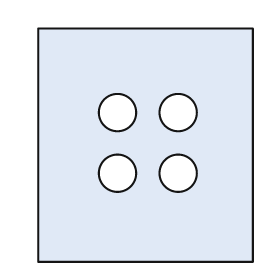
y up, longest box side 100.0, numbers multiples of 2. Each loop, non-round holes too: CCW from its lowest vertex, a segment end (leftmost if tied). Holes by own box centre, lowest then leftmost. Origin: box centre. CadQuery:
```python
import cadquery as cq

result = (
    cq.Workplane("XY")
    .moveTo(-46.0, -50.0)
    .lineTo(46.0, -50.0)
    .lineTo(46.0, 50.0)
    .lineTo(-46.0, 50.0)
    .close()
    .moveTo(-12.0, -12.0)
    .circle(8.0)
    .moveTo(14.0, -12.0)
    .circle(8.0)
    .moveTo(-12.0, 14.0)
    .circle(8.0)
    .moveTo(14.0, 14.0)
    .circle(8.0)
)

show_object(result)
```